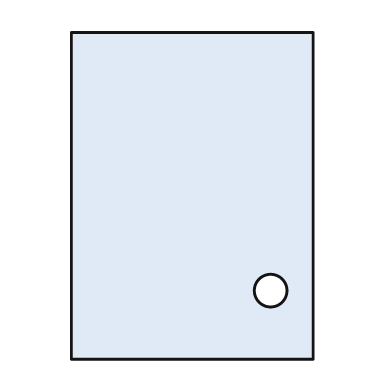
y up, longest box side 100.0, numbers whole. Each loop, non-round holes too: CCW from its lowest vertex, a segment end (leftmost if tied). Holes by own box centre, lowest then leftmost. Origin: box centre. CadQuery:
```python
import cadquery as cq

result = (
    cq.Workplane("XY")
    .moveTo(-37.0, -50.0)
    .lineTo(37.0, -50.0)
    .lineTo(37.0, 50.0)
    .lineTo(-37.0, 50.0)
    .close()
    .moveTo(24.0, -29.0)
    .circle(5.0)
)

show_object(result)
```